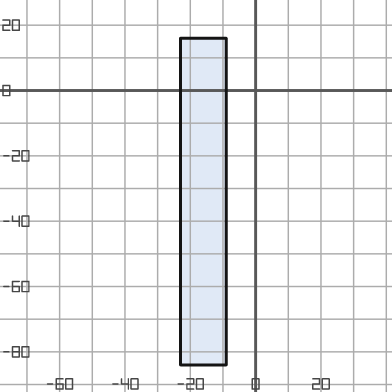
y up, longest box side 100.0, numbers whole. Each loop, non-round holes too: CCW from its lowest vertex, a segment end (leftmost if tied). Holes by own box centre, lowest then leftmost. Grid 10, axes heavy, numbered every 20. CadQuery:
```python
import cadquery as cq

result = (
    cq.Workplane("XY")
    .moveTo(-23.0, -84.0)
    .lineTo(-9.0, -84.0)
    .lineTo(-9.0, 16.0)
    .lineTo(-23.0, 16.0)
    .close()
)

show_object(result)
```